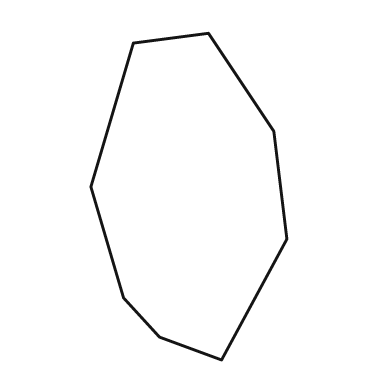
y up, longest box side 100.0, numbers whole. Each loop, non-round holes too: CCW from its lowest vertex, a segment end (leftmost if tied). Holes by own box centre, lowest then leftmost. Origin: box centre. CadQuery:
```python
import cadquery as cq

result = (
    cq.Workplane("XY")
    .moveTo(10.0, -50.0)
    .lineTo(30.0, -13.0)
    .lineTo(26.0, 20.0)
    .lineTo(6.0, 50.0)
    .lineTo(-17.0, 47.0)
    .lineTo(-30.0, 3.0)
    .lineTo(-20.0, -31.0)
    .lineTo(-9.0, -43.0)
    .close()
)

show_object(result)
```